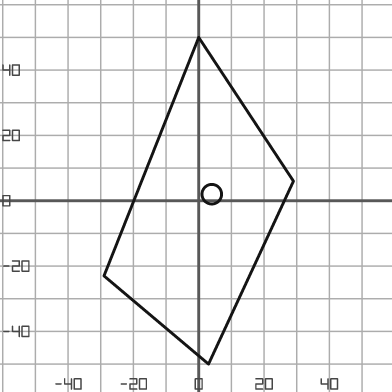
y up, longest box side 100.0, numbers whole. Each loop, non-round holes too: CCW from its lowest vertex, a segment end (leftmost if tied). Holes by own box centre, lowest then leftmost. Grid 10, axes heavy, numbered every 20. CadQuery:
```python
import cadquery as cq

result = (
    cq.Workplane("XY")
    .moveTo(3.0, -50.0)
    .lineTo(29.0, 6.0)
    .lineTo(0.0, 50.0)
    .lineTo(-29.0, -23.0)
    .close()
    .moveTo(4.0, 2.0)
    .circle(3.0)
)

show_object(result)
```